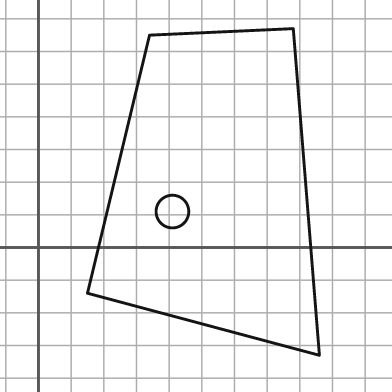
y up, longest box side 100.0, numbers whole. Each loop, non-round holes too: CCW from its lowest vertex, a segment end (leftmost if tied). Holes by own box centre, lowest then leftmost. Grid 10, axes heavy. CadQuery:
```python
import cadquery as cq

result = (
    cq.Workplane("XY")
    .moveTo(86.0, -33.0)
    .lineTo(78.0, 67.0)
    .lineTo(34.0, 65.0)
    .lineTo(15.0, -14.0)
    .close()
    .moveTo(41.0, 11.0)
    .circle(5.0)
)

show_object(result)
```